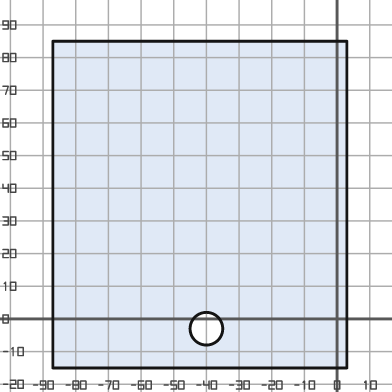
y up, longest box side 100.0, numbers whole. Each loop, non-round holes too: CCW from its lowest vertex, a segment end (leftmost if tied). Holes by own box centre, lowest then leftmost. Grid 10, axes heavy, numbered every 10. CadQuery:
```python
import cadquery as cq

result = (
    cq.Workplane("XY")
    .moveTo(-87.0, -15.0)
    .lineTo(3.0, -15.0)
    .lineTo(3.0, 85.0)
    .lineTo(-87.0, 85.0)
    .close()
    .moveTo(-40.0, -3.0)
    .circle(5.0)
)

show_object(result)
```